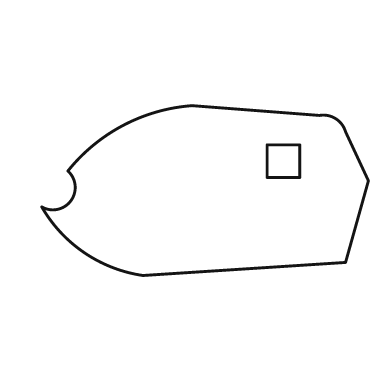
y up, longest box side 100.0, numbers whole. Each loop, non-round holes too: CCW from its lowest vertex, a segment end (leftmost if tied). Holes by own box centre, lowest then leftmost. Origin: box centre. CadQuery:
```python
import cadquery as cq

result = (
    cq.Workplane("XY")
    .moveTo(-19.0, -26.0)
    .lineTo(43.0, -22.0)
    .lineTo(50.0, 3.0)
    .lineTo(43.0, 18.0)
    .threePointArc((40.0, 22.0), (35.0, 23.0))
    .lineTo(-4.0, 26.0)
    .threePointArc((-25.0, 20.0), (-42.0, 6.0))
    .threePointArc((-41.0, -3.0), (-50.0, -5.0))
    .threePointArc((-37.0, -19.0), (-19.0, -26.0))
    .close()
    .moveTo(19.0, 4.0)
    .lineTo(29.0, 4.0)
    .lineTo(29.0, 14.0)
    .lineTo(19.0, 14.0)
    .close()
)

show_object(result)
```